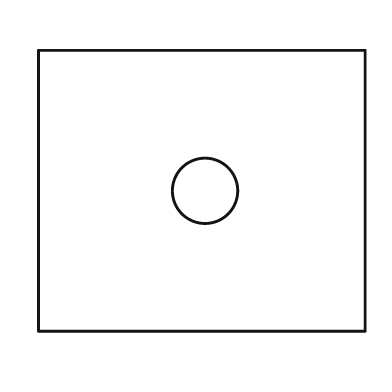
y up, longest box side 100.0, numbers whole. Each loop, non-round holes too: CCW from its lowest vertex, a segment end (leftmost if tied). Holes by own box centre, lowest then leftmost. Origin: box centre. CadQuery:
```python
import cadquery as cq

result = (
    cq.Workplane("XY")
    .moveTo(-50.0, -43.0)
    .lineTo(50.0, -43.0)
    .lineTo(50.0, 43.0)
    .lineTo(-50.0, 43.0)
    .close()
    .moveTo(1.0, 0.0)
    .circle(10.0)
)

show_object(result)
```